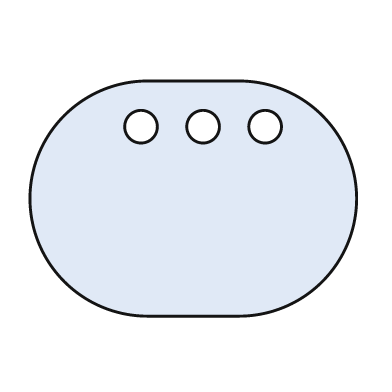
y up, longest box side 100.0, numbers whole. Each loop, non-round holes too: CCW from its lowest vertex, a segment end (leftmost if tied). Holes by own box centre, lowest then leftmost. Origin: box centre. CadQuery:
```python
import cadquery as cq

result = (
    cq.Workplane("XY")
    .moveTo(-14.0, -36.0)
    .lineTo(14.0, -36.0)
    .threePointArc((50.0, 0.0), (14.0, 36.0))
    .lineTo(-14.0, 36.0)
    .threePointArc((-50.0, 0.0), (-14.0, -36.0))
    .close()
    .moveTo(-16.0, 22.0)
    .circle(5.0)
    .moveTo(3.0, 22.0)
    .circle(5.0)
    .moveTo(22.0, 22.0)
    .circle(5.0)
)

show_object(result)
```